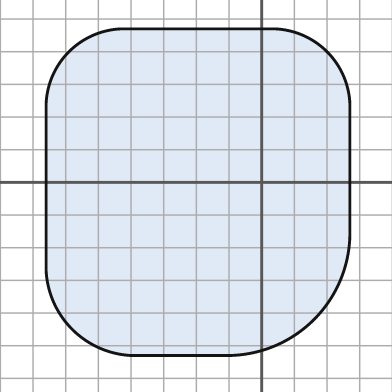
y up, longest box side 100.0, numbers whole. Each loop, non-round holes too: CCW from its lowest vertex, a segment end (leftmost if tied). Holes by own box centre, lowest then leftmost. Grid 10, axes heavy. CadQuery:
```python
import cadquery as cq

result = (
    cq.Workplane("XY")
    .moveTo(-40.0, -53.0)
    .lineTo(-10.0, -53.0)
    .threePointArc((16.0, -42.0), (27.0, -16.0))
    .lineTo(27.0, 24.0)
    .threePointArc((20.0, 40.0), (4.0, 47.0))
    .lineTo(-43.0, 47.0)
    .threePointArc((-59.0, 40.0), (-66.0, 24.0))
    .lineTo(-66.0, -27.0)
    .threePointArc((-58.0, -45.0), (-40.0, -53.0))
    .close()
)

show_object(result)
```